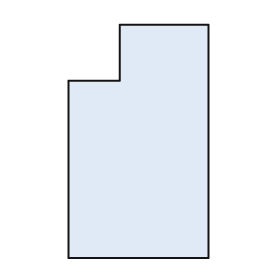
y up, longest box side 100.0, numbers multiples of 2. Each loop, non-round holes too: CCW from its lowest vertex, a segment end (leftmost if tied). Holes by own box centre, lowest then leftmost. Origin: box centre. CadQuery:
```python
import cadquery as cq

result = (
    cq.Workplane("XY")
    .moveTo(-30.0, -50.0)
    .lineTo(30.0, -50.0)
    .lineTo(30.0, 50.0)
    .lineTo(-8.0, 50.0)
    .lineTo(-8.0, 26.0)
    .lineTo(-30.0, 26.0)
    .close()
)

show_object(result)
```